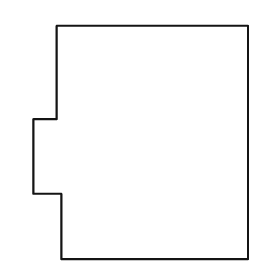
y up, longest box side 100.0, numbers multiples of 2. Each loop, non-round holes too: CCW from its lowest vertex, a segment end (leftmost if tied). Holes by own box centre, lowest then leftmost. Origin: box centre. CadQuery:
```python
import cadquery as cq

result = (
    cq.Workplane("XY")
    .moveTo(-34.0, -50.0)
    .lineTo(46.0, -50.0)
    .lineTo(46.0, 50.0)
    .lineTo(-36.0, 50.0)
    .lineTo(-36.0, 10.0)
    .lineTo(-46.0, 10.0)
    .lineTo(-46.0, -22.0)
    .lineTo(-34.0, -22.0)
    .close()
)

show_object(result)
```